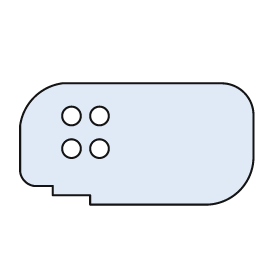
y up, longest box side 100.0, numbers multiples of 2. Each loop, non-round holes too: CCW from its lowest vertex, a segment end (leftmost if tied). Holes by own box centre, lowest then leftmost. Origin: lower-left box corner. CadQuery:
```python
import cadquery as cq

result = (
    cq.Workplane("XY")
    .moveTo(30.0, 0.0)
    .lineTo(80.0, 0.0)
    .threePointArc((94.0, 6.0), (100.0, 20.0))
    .lineTo(100.0, 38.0)
    .threePointArc((96.0, 48.0), (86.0, 52.0))
    .lineTo(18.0, 52.0)
    .threePointArc((6.0, 46.0), (0.0, 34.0))
    .lineTo(0.0, 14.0)
    .threePointArc((2.0, 10.0), (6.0, 8.0))
    .lineTo(14.0, 8.0)
    .lineTo(14.0, 4.0)
    .lineTo(30.0, 4.0)
    .close()
    .moveTo(22.0, 24.0)
    .circle(4.0)
    .moveTo(34.0, 24.0)
    .circle(4.0)
    .moveTo(22.0, 38.0)
    .circle(4.0)
    .moveTo(34.0, 38.0)
    .circle(4.0)
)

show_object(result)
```